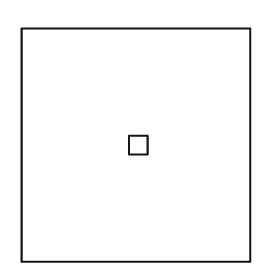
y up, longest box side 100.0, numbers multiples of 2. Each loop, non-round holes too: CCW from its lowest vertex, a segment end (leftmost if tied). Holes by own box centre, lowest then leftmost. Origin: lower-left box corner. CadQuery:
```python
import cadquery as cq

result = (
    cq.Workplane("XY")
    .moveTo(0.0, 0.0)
    .lineTo(98.0, 0.0)
    .lineTo(98.0, 100.0)
    .lineTo(0.0, 100.0)
    .close()
    .moveTo(46.0, 46.0)
    .lineTo(54.0, 46.0)
    .lineTo(54.0, 54.0)
    .lineTo(46.0, 54.0)
    .close()
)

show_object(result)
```